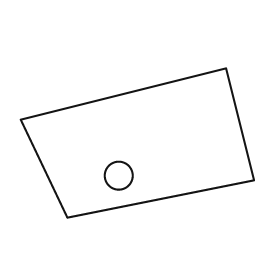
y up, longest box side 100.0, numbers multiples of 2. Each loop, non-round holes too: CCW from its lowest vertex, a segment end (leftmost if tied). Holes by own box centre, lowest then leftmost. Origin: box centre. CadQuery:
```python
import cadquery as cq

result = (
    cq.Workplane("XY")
    .moveTo(-30.0, -32.0)
    .lineTo(50.0, -16.0)
    .lineTo(38.0, 32.0)
    .lineTo(-50.0, 10.0)
    .close()
    .moveTo(-8.0, -14.0)
    .circle(6.0)
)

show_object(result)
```